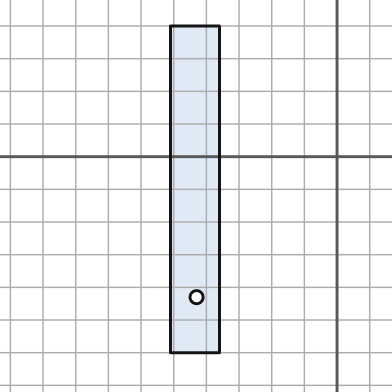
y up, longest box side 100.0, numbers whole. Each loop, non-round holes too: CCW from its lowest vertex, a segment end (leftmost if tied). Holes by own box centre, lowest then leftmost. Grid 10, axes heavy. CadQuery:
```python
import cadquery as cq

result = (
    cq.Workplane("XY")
    .moveTo(-51.0, -60.0)
    .lineTo(-36.0, -60.0)
    .lineTo(-36.0, 40.0)
    .lineTo(-51.0, 40.0)
    .close()
    .moveTo(-43.0, -43.0)
    .circle(2.0)
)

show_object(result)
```